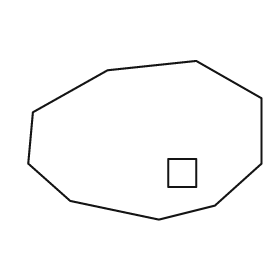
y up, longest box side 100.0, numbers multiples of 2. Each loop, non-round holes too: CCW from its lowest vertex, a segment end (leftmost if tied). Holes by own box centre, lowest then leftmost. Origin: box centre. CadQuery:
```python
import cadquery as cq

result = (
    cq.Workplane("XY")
    .moveTo(6.0, -34.0)
    .lineTo(30.0, -28.0)
    .lineTo(50.0, -10.0)
    .lineTo(50.0, 18.0)
    .lineTo(22.0, 34.0)
    .lineTo(-16.0, 30.0)
    .lineTo(-48.0, 12.0)
    .lineTo(-50.0, -10.0)
    .lineTo(-32.0, -26.0)
    .close()
    .moveTo(10.0, -20.0)
    .lineTo(22.0, -20.0)
    .lineTo(22.0, -8.0)
    .lineTo(10.0, -8.0)
    .close()
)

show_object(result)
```